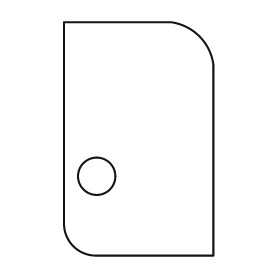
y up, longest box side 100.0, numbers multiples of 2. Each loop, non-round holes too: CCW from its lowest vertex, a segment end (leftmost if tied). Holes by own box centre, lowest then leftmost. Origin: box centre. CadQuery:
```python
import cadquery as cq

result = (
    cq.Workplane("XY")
    .moveTo(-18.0, -50.0)
    .lineTo(32.0, -50.0)
    .lineTo(32.0, 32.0)
    .threePointArc((26.0, 44.0), (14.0, 50.0))
    .lineTo(-32.0, 50.0)
    .lineTo(-32.0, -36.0)
    .threePointArc((-28.0, -46.0), (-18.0, -50.0))
    .close()
    .moveTo(-18.0, -16.0)
    .circle(8.0)
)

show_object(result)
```